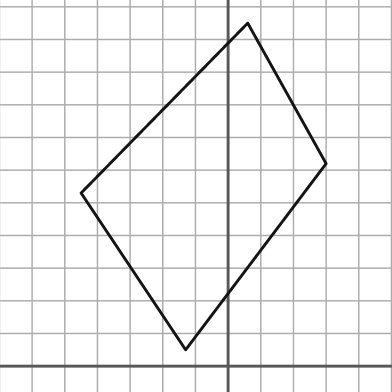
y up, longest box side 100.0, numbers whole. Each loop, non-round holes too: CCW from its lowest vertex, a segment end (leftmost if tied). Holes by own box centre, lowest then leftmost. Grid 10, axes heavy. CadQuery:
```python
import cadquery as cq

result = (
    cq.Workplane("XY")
    .moveTo(-13.0, 5.0)
    .lineTo(30.0, 62.0)
    .lineTo(6.0, 105.0)
    .lineTo(-45.0, 53.0)
    .close()
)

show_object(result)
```